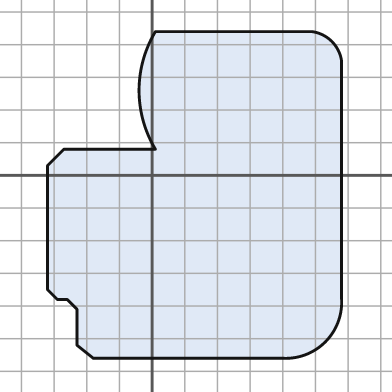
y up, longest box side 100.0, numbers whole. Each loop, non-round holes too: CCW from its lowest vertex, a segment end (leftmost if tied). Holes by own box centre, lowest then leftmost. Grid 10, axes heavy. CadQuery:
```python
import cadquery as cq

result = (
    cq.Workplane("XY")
    .moveTo(-18.0, -56.0)
    .lineTo(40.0, -56.0)
    .threePointArc((53.0, -51.0), (58.0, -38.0))
    .lineTo(58.0, 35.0)
    .threePointArc((55.0, 41.0), (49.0, 44.0))
    .lineTo(1.0, 44.0)
    .threePointArc((-4.0, 26.0), (1.0, 8.0))
    .lineTo(-27.0, 8.0)
    .lineTo(-32.0, 3.0)
    .lineTo(-32.0, -35.0)
    .lineTo(-29.0, -38.0)
    .lineTo(-26.0, -38.0)
    .lineTo(-23.0, -41.0)
    .lineTo(-23.0, -52.0)
    .close()
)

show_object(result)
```